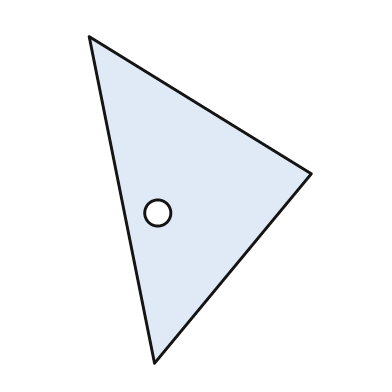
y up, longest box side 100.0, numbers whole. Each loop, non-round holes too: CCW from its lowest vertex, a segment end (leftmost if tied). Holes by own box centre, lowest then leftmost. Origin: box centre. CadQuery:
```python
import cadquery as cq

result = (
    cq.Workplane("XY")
    .moveTo(-14.0, -50.0)
    .lineTo(34.0, 8.0)
    .lineTo(-34.0, 50.0)
    .close()
    .moveTo(-13.0, -4.0)
    .circle(4.0)
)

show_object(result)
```